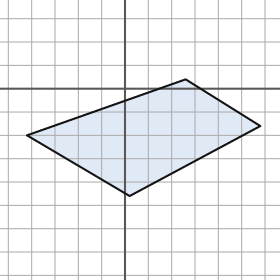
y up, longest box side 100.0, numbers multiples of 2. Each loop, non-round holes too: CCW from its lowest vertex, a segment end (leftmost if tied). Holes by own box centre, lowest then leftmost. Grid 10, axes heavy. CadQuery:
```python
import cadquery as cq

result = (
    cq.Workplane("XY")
    .moveTo(2.0, -46.0)
    .lineTo(58.0, -16.0)
    .lineTo(26.0, 4.0)
    .lineTo(-42.0, -20.0)
    .close()
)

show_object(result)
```